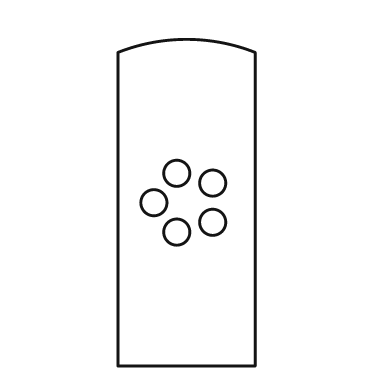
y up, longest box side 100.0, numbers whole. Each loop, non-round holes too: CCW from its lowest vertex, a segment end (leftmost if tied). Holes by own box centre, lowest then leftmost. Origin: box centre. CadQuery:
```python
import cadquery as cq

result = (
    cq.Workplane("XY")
    .moveTo(-21.0, -50.0)
    .lineTo(21.0, -50.0)
    .lineTo(21.0, 46.0)
    .threePointArc((0.0, 50.0), (-21.0, 46.0))
    .close()
    .moveTo(-3.0, -9.0)
    .circle(4.0)
    .moveTo(8.0, -6.0)
    .circle(4.0)
    .moveTo(-10.0, 0.0)
    .circle(4.0)
    .moveTo(8.0, 6.0)
    .circle(4.0)
    .moveTo(-3.0, 9.0)
    .circle(4.0)
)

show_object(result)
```